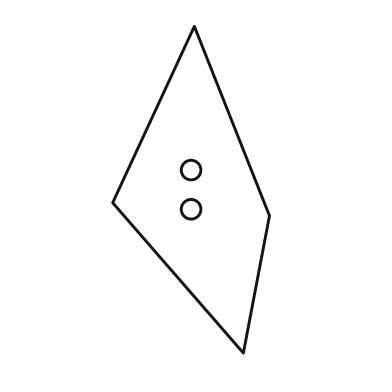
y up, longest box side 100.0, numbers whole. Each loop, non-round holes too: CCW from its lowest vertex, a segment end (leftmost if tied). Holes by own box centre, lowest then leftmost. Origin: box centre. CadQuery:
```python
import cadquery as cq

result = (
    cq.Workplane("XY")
    .moveTo(16.0, -50.0)
    .lineTo(24.0, -8.0)
    .lineTo(1.0, 50.0)
    .lineTo(-24.0, -4.0)
    .close()
    .moveTo(0.0, -6.0)
    .circle(3.0)
    .moveTo(0.0, 6.0)
    .circle(3.0)
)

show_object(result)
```